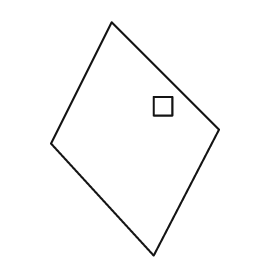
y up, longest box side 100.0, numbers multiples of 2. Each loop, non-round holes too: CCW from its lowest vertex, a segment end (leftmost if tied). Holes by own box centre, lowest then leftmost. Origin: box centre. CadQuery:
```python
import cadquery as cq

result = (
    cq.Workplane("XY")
    .moveTo(8.0, -50.0)
    .lineTo(36.0, 4.0)
    .lineTo(-10.0, 50.0)
    .lineTo(-36.0, -2.0)
    .close()
    .moveTo(8.0, 10.0)
    .lineTo(16.0, 10.0)
    .lineTo(16.0, 18.0)
    .lineTo(8.0, 18.0)
    .close()
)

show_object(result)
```